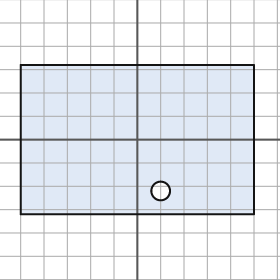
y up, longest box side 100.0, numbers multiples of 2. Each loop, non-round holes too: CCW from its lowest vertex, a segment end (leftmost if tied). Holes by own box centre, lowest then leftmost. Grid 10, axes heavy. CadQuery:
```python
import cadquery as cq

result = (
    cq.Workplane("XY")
    .moveTo(-50.0, -32.0)
    .lineTo(50.0, -32.0)
    .lineTo(50.0, 32.0)
    .lineTo(-50.0, 32.0)
    .close()
    .moveTo(10.0, -22.0)
    .circle(4.0)
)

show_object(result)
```